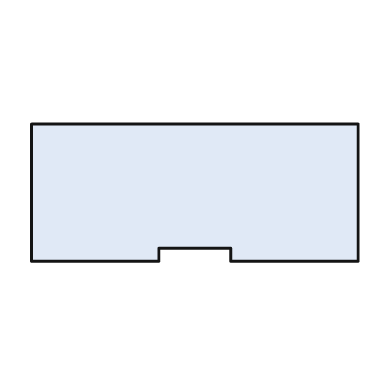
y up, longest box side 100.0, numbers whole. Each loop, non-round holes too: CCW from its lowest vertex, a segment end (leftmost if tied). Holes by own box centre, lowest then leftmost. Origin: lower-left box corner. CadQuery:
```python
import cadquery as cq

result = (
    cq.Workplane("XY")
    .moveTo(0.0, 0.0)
    .lineTo(39.0, 0.0)
    .lineTo(39.0, 4.0)
    .lineTo(61.0, 4.0)
    .lineTo(61.0, 0.0)
    .lineTo(100.0, 0.0)
    .lineTo(100.0, 42.0)
    .lineTo(0.0, 42.0)
    .close()
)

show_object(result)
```